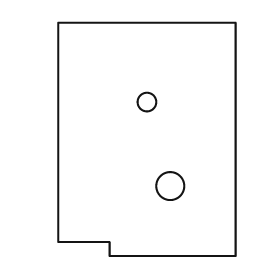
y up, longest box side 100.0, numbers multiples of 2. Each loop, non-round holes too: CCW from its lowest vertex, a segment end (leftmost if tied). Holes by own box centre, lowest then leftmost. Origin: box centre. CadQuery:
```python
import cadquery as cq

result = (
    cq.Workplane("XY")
    .moveTo(-16.0, -50.0)
    .lineTo(38.0, -50.0)
    .lineTo(38.0, 50.0)
    .lineTo(-38.0, 50.0)
    .lineTo(-38.0, -44.0)
    .lineTo(-16.0, -44.0)
    .close()
    .moveTo(10.0, -20.0)
    .circle(6.0)
    .moveTo(0.0, 16.0)
    .circle(4.0)
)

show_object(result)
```